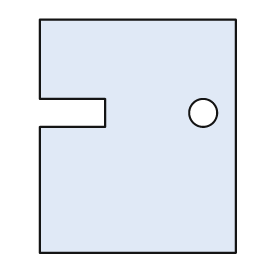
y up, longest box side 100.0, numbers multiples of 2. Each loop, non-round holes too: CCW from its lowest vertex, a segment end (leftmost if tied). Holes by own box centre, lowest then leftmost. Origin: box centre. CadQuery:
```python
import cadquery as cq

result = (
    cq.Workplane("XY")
    .moveTo(-42.0, -50.0)
    .lineTo(42.0, -50.0)
    .lineTo(42.0, 50.0)
    .lineTo(-42.0, 50.0)
    .lineTo(-42.0, 16.0)
    .lineTo(-14.0, 16.0)
    .lineTo(-14.0, 4.0)
    .lineTo(-42.0, 4.0)
    .close()
    .moveTo(28.0, 10.0)
    .circle(6.0)
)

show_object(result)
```